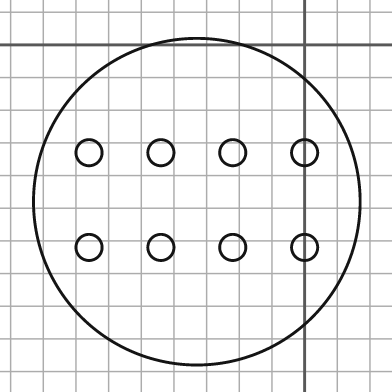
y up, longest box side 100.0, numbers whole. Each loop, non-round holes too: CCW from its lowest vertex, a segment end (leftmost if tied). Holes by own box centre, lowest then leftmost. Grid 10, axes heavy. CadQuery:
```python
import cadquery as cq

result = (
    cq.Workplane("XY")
    .moveTo(-33.0, -48.0)
    .circle(50.0)
    .moveTo(-66.0, -62.0)
    .circle(4.0)
    .moveTo(-44.0, -62.0)
    .circle(4.0)
    .moveTo(-22.0, -62.0)
    .circle(4.0)
    .moveTo(0.0, -62.0)
    .circle(4.0)
    .moveTo(-66.0, -33.0)
    .circle(4.0)
    .moveTo(-44.0, -33.0)
    .circle(4.0)
    .moveTo(-22.0, -33.0)
    .circle(4.0)
    .moveTo(0.0, -33.0)
    .circle(4.0)
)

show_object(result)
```